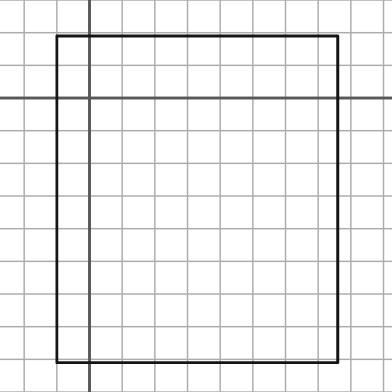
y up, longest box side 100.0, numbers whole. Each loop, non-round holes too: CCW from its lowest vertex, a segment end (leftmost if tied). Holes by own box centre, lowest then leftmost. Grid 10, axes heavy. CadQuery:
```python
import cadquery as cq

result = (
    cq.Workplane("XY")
    .moveTo(-10.0, -81.0)
    .lineTo(76.0, -81.0)
    .lineTo(76.0, 19.0)
    .lineTo(-10.0, 19.0)
    .close()
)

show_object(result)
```